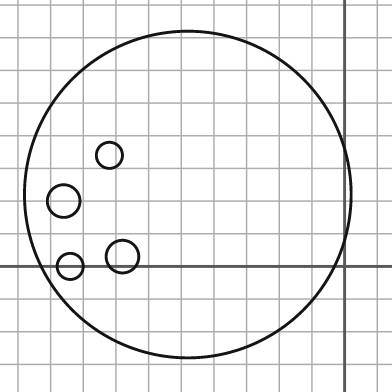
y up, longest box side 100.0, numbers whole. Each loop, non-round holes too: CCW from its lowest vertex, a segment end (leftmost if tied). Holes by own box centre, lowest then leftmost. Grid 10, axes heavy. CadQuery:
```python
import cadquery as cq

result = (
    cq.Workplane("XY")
    .moveTo(-48.0, 22.0)
    .circle(50.0)
    .moveTo(-84.0, 0.0)
    .circle(4.0)
    .moveTo(-68.0, 3.0)
    .circle(5.0)
    .moveTo(-86.0, 20.0)
    .circle(5.0)
    .moveTo(-72.0, 34.0)
    .circle(4.0)
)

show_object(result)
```